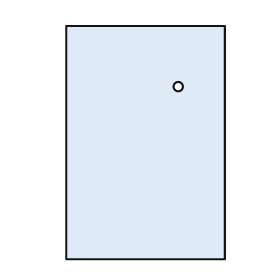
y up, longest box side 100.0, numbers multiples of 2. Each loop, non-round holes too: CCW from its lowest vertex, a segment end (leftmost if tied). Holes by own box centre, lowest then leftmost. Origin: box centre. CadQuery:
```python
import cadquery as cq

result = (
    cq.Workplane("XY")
    .moveTo(-34.0, -50.0)
    .lineTo(34.0, -50.0)
    .lineTo(34.0, 50.0)
    .lineTo(-34.0, 50.0)
    .close()
    .moveTo(14.0, 24.0)
    .circle(2.0)
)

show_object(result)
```